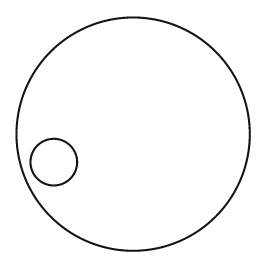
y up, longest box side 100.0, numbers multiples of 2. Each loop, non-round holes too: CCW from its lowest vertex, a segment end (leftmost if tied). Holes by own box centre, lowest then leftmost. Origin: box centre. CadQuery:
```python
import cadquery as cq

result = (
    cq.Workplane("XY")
    .moveTo(0.0, 0.0)
    .circle(50.0)
    .moveTo(-34.0, -12.0)
    .circle(10.0)
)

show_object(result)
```